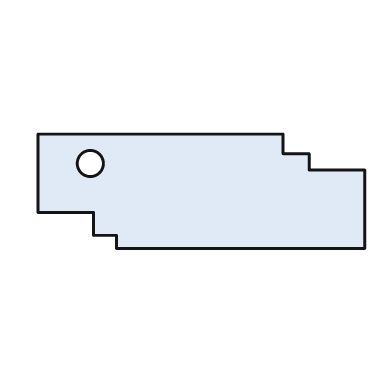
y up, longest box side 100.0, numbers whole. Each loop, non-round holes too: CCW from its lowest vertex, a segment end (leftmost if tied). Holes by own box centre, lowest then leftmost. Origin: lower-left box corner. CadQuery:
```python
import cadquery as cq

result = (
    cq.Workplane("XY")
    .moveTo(24.0, 0.0)
    .lineTo(100.0, 0.0)
    .lineTo(100.0, 24.0)
    .lineTo(83.0, 24.0)
    .lineTo(83.0, 29.0)
    .lineTo(75.0, 29.0)
    .lineTo(75.0, 35.0)
    .lineTo(0.0, 35.0)
    .lineTo(0.0, 11.0)
    .lineTo(17.0, 11.0)
    .lineTo(17.0, 4.0)
    .lineTo(24.0, 4.0)
    .close()
    .moveTo(16.0, 26.0)
    .circle(4.0)
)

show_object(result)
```